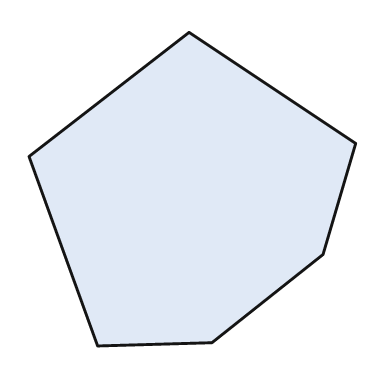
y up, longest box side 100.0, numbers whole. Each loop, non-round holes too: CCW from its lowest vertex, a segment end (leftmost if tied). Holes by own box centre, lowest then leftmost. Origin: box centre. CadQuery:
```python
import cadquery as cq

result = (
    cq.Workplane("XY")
    .moveTo(-29.0, -48.0)
    .lineTo(6.0, -47.0)
    .lineTo(40.0, -20.0)
    .lineTo(50.0, 14.0)
    .lineTo(-1.0, 48.0)
    .lineTo(-50.0, 10.0)
    .close()
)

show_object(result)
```